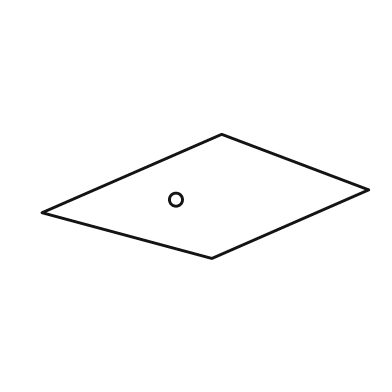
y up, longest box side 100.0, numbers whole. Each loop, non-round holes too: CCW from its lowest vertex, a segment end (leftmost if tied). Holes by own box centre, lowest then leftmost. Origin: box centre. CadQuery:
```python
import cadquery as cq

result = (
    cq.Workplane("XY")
    .moveTo(2.0, -19.0)
    .lineTo(50.0, 2.0)
    .lineTo(5.0, 19.0)
    .lineTo(-50.0, -5.0)
    .close()
    .moveTo(-9.0, -1.0)
    .circle(2.0)
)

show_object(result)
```